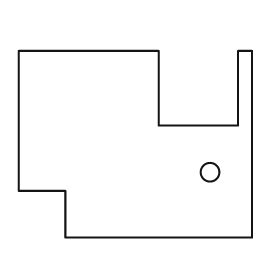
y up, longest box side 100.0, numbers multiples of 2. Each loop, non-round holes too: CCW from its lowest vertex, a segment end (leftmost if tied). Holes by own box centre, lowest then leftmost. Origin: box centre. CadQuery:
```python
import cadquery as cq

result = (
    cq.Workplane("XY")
    .moveTo(-30.0, -40.0)
    .lineTo(50.0, -40.0)
    .lineTo(50.0, 40.0)
    .lineTo(44.0, 40.0)
    .lineTo(44.0, 8.0)
    .lineTo(10.0, 8.0)
    .lineTo(10.0, 40.0)
    .lineTo(-50.0, 40.0)
    .lineTo(-50.0, -20.0)
    .lineTo(-30.0, -20.0)
    .close()
    .moveTo(32.0, -12.0)
    .circle(4.0)
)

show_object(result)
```